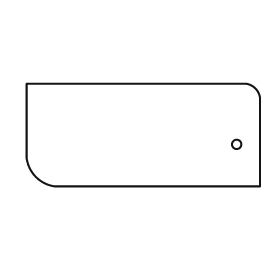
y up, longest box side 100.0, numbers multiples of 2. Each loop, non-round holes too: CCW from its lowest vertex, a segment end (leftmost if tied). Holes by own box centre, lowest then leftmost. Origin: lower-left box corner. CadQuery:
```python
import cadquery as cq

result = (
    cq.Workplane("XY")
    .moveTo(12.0, 0.0)
    .lineTo(100.0, 0.0)
    .lineTo(100.0, 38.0)
    .threePointArc((98.0, 42.0), (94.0, 44.0))
    .lineTo(0.0, 44.0)
    .lineTo(0.0, 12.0)
    .threePointArc((4.0, 4.0), (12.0, 0.0))
    .close()
    .moveTo(90.0, 18.0)
    .circle(2.0)
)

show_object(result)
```